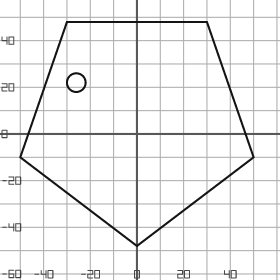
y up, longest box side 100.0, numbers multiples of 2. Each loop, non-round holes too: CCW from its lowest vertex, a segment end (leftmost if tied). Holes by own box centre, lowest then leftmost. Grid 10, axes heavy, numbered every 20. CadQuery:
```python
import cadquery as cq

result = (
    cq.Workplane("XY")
    .moveTo(0.0, -48.0)
    .lineTo(50.0, -10.0)
    .lineTo(30.0, 48.0)
    .lineTo(-30.0, 48.0)
    .lineTo(-50.0, -10.0)
    .close()
    .moveTo(-26.0, 22.0)
    .circle(4.0)
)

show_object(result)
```